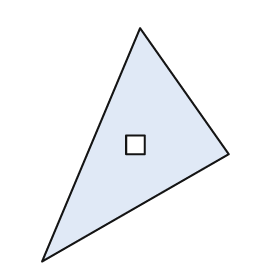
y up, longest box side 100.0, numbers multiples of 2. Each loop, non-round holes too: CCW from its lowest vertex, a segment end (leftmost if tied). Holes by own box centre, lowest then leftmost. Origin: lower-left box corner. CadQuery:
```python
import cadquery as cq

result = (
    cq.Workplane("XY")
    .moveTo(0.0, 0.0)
    .lineTo(80.0, 46.0)
    .lineTo(42.0, 100.0)
    .close()
    .moveTo(36.0, 46.0)
    .lineTo(44.0, 46.0)
    .lineTo(44.0, 54.0)
    .lineTo(36.0, 54.0)
    .close()
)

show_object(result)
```